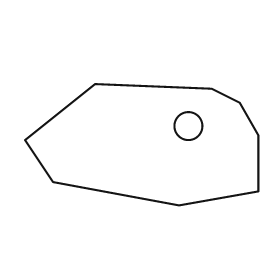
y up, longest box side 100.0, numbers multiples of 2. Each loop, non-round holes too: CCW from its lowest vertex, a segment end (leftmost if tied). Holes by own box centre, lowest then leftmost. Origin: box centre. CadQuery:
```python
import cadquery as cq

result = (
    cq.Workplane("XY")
    .moveTo(16.0, -26.0)
    .lineTo(50.0, -20.0)
    .lineTo(50.0, 4.0)
    .lineTo(42.0, 18.0)
    .lineTo(30.0, 24.0)
    .lineTo(-20.0, 26.0)
    .lineTo(-50.0, 2.0)
    .lineTo(-38.0, -16.0)
    .close()
    .moveTo(20.0, 8.0)
    .circle(6.0)
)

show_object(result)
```